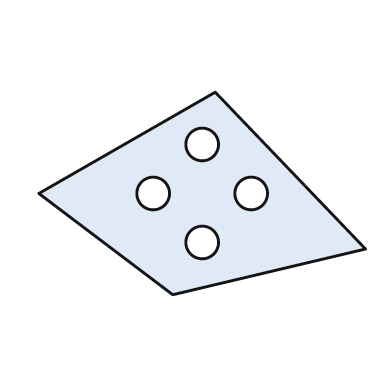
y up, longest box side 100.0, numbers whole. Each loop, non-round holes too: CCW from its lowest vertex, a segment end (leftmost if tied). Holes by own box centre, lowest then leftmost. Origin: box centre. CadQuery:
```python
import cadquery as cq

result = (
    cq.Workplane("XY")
    .moveTo(-9.0, -31.0)
    .lineTo(50.0, -17.0)
    .lineTo(4.0, 31.0)
    .lineTo(-50.0, 0.0)
    .close()
    .moveTo(0.0, -15.0)
    .circle(5.0)
    .moveTo(-15.0, 0.0)
    .circle(5.0)
    .moveTo(15.0, 0.0)
    .circle(5.0)
    .moveTo(0.0, 15.0)
    .circle(5.0)
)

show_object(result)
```